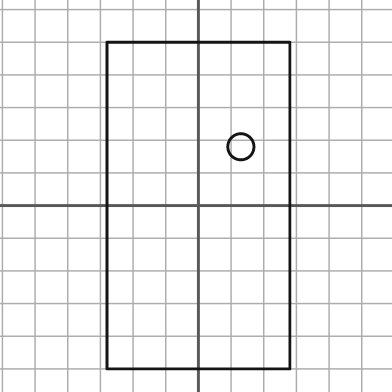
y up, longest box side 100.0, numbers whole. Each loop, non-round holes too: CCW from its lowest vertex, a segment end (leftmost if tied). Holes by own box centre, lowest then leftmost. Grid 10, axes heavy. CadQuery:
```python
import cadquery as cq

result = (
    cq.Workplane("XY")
    .moveTo(-28.0, -50.0)
    .lineTo(28.0, -50.0)
    .lineTo(28.0, 50.0)
    .lineTo(-28.0, 50.0)
    .close()
    .moveTo(13.0, 18.0)
    .circle(4.0)
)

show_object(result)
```